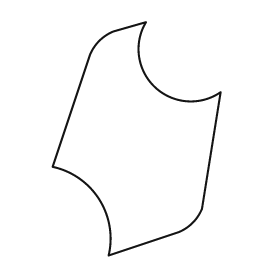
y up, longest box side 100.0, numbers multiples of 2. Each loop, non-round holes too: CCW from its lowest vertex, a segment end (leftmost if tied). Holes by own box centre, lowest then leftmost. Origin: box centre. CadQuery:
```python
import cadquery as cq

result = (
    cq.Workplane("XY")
    .moveTo(-12.0, -50.0)
    .lineTo(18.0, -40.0)
    .threePointArc((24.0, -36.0), (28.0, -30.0))
    .lineTo(36.0, 20.0)
    .threePointArc((8.0, 22.0), (4.0, 50.0))
    .lineTo(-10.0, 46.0)
    .threePointArc((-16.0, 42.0), (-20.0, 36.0))
    .lineTo(-36.0, -12.0)
    .threePointArc((-16.0, -26.0), (-12.0, -50.0))
    .close()
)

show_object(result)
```